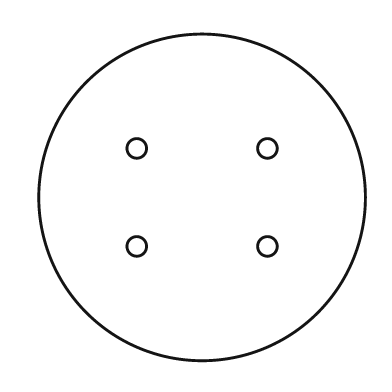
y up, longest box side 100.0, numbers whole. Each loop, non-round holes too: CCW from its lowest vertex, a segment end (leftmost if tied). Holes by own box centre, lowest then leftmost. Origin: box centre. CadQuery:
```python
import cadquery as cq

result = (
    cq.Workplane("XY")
    .moveTo(0.0, 0.0)
    .circle(50.0)
    .moveTo(-20.0, -15.0)
    .circle(3.0)
    .moveTo(20.0, -15.0)
    .circle(3.0)
    .moveTo(-20.0, 15.0)
    .circle(3.0)
    .moveTo(20.0, 15.0)
    .circle(3.0)
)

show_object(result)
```